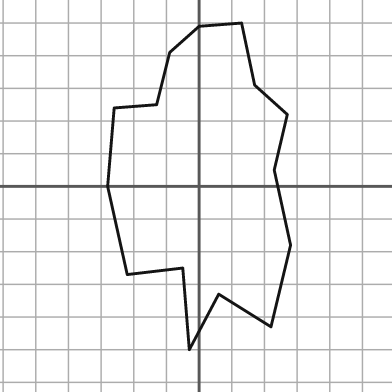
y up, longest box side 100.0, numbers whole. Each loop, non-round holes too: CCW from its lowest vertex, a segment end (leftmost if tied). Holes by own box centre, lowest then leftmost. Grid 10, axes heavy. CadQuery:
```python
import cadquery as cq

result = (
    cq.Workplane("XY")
    .moveTo(-3.0, -50.0)
    .lineTo(6.0, -33.0)
    .lineTo(22.0, -43.0)
    .lineTo(28.0, -18.0)
    .lineTo(23.0, 5.0)
    .lineTo(27.0, 22.0)
    .lineTo(17.0, 31.0)
    .lineTo(13.0, 50.0)
    .lineTo(0.0, 49.0)
    .lineTo(-9.0, 41.0)
    .lineTo(-13.0, 25.0)
    .lineTo(-26.0, 24.0)
    .lineTo(-28.0, 0.0)
    .lineTo(-22.0, -27.0)
    .lineTo(-5.0, -25.0)
    .close()
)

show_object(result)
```